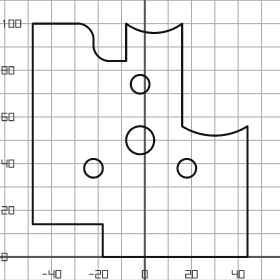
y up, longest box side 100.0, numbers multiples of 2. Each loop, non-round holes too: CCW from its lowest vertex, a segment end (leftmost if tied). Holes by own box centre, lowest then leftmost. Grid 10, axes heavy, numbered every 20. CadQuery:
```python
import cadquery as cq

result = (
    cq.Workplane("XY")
    .moveTo(-18.0, 0.0)
    .lineTo(44.0, 0.0)
    .lineTo(44.0, 56.0)
    .threePointArc((30.0, 52.0), (16.0, 56.0))
    .lineTo(16.0, 100.0)
    .threePointArc((4.0, 96.0), (-8.0, 100.0))
    .lineTo(-8.0, 84.0)
    .lineTo(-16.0, 84.0)
    .threePointArc((-20.0, 86.0), (-22.0, 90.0))
    .lineTo(-22.0, 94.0)
    .threePointArc((-24.0, 98.0), (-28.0, 100.0))
    .lineTo(-48.0, 100.0)
    .lineTo(-48.0, 14.0)
    .lineTo(-18.0, 14.0)
    .close()
    .moveTo(-22.0, 38.0)
    .circle(4.0)
    .moveTo(18.0, 38.0)
    .circle(4.0)
    .moveTo(-2.0, 50.0)
    .circle(6.0)
    .moveTo(-2.0, 74.0)
    .circle(4.0)
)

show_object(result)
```